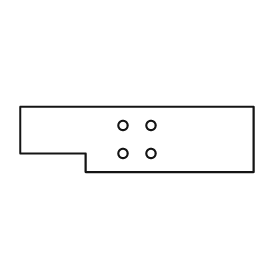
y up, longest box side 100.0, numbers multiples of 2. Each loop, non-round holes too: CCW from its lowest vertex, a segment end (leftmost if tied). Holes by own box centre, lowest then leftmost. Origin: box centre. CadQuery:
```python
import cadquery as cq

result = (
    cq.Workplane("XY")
    .moveTo(-22.0, -14.0)
    .lineTo(50.0, -14.0)
    .lineTo(50.0, 14.0)
    .lineTo(-50.0, 14.0)
    .lineTo(-50.0, -6.0)
    .lineTo(-22.0, -6.0)
    .close()
    .moveTo(-6.0, -6.0)
    .circle(2.0)
    .moveTo(6.0, -6.0)
    .circle(2.0)
    .moveTo(-6.0, 6.0)
    .circle(2.0)
    .moveTo(6.0, 6.0)
    .circle(2.0)
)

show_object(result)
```